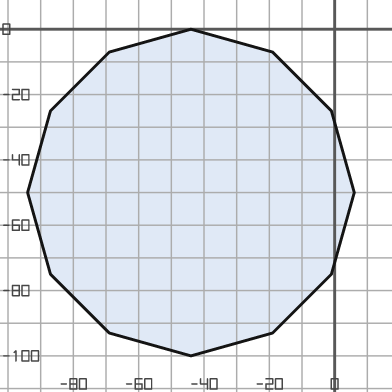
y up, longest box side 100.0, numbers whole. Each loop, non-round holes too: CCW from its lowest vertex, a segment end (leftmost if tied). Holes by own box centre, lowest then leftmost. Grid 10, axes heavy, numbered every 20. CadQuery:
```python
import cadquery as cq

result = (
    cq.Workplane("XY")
    .moveTo(-44.0, -100.0)
    .lineTo(-19.0, -93.0)
    .lineTo(-1.0, -75.0)
    .lineTo(6.0, -50.0)
    .lineTo(-1.0, -25.0)
    .lineTo(-19.0, -7.0)
    .lineTo(-44.0, 0.0)
    .lineTo(-69.0, -7.0)
    .lineTo(-87.0, -25.0)
    .lineTo(-94.0, -50.0)
    .lineTo(-87.0, -75.0)
    .lineTo(-69.0, -93.0)
    .close()
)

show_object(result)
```